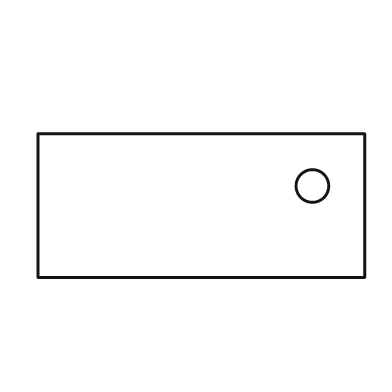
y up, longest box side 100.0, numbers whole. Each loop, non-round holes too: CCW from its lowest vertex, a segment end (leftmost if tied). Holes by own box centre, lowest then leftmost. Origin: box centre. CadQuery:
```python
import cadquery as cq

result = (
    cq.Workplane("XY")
    .moveTo(-50.0, -22.0)
    .lineTo(50.0, -22.0)
    .lineTo(50.0, 22.0)
    .lineTo(-50.0, 22.0)
    .close()
    .moveTo(34.0, 6.0)
    .circle(5.0)
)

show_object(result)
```